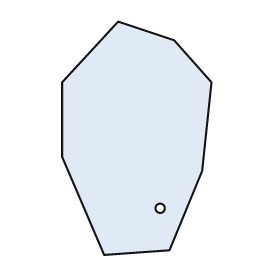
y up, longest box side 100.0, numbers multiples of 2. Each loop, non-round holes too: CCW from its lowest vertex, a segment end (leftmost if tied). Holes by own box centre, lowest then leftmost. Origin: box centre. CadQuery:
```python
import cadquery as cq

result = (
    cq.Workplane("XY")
    .moveTo(-14.0, -50.0)
    .lineTo(14.0, -48.0)
    .lineTo(28.0, -14.0)
    .lineTo(32.0, 24.0)
    .lineTo(16.0, 42.0)
    .lineTo(-8.0, 50.0)
    .lineTo(-32.0, 24.0)
    .lineTo(-32.0, -8.0)
    .close()
    .moveTo(10.0, -30.0)
    .circle(2.0)
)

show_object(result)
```